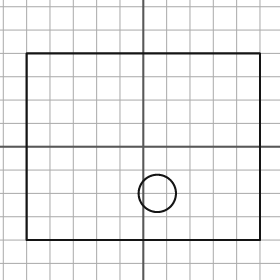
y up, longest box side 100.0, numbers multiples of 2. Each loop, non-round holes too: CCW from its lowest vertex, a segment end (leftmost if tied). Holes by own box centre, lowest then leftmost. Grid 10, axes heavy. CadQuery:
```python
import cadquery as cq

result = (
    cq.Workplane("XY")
    .moveTo(-50.0, -40.0)
    .lineTo(50.0, -40.0)
    .lineTo(50.0, 40.0)
    .lineTo(-50.0, 40.0)
    .close()
    .moveTo(6.0, -20.0)
    .circle(8.0)
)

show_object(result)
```